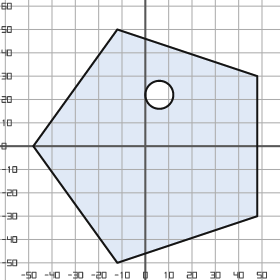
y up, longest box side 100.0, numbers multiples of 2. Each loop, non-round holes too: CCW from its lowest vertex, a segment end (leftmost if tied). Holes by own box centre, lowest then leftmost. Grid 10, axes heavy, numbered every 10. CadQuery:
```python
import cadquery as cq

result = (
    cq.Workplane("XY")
    .moveTo(-12.0, -50.0)
    .lineTo(48.0, -30.0)
    .lineTo(48.0, 30.0)
    .lineTo(-12.0, 50.0)
    .lineTo(-48.0, 0.0)
    .close()
    .moveTo(6.0, 22.0)
    .circle(6.0)
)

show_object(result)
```